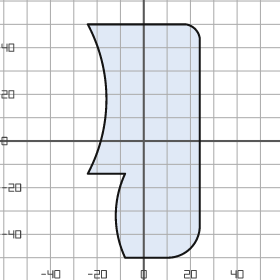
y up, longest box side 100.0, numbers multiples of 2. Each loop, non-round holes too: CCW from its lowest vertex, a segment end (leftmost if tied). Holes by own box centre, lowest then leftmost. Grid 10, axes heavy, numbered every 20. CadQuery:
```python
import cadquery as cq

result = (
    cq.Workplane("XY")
    .moveTo(-8.0, -50.0)
    .lineTo(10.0, -50.0)
    .threePointArc((20.0, -46.0), (24.0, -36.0))
    .lineTo(24.0, 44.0)
    .threePointArc((22.0, 48.0), (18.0, 50.0))
    .lineTo(-24.0, 50.0)
    .threePointArc((-16.0, 18.0), (-24.0, -14.0))
    .lineTo(-8.0, -14.0)
    .threePointArc((-12.0, -32.0), (-8.0, -50.0))
    .close()
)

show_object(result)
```